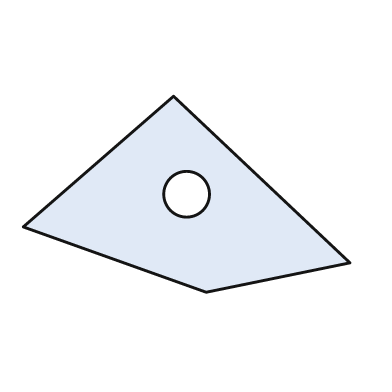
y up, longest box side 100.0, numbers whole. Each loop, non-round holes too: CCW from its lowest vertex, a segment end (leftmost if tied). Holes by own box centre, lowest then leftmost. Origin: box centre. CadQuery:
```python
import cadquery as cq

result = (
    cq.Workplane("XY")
    .moveTo(6.0, -30.0)
    .lineTo(50.0, -21.0)
    .lineTo(-4.0, 30.0)
    .lineTo(-50.0, -10.0)
    .close()
    .moveTo(0.0, 0.0)
    .circle(7.0)
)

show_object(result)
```